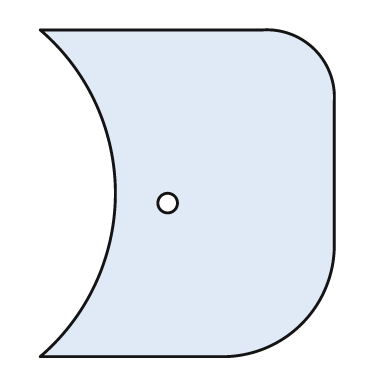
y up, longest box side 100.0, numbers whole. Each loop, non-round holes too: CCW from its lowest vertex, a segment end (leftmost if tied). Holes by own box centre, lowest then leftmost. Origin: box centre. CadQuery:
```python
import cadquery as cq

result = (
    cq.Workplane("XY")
    .moveTo(-45.0, -50.0)
    .lineTo(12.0, -50.0)
    .threePointArc((35.0, -40.0), (45.0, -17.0))
    .lineTo(45.0, 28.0)
    .threePointArc((39.0, 44.0), (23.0, 50.0))
    .lineTo(-45.0, 50.0)
    .threePointArc((-22.0, 0.0), (-45.0, -50.0))
    .close()
    .moveTo(-6.0, -3.0)
    .circle(3.0)
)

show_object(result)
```